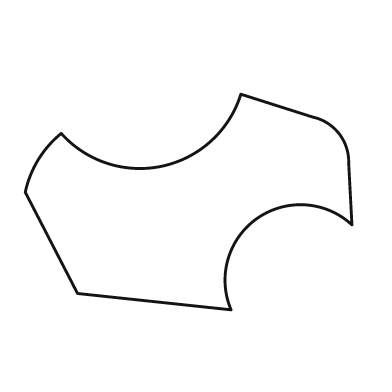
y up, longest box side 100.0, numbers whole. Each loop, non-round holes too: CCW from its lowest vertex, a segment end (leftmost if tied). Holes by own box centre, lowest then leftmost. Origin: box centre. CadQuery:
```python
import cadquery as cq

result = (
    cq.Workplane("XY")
    .moveTo(13.0, -33.0)
    .threePointArc((21.0, -5.0), (50.0, -7.0))
    .lineTo(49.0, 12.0)
    .threePointArc((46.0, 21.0), (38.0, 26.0))
    .lineTo(16.0, 33.0)
    .threePointArc((-8.0, 11.0), (-39.0, 21.0))
    .threePointArc((-46.0, 13.0), (-50.0, 3.0))
    .lineTo(-34.0, -28.0)
    .close()
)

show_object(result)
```